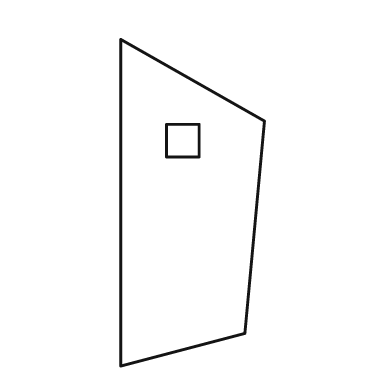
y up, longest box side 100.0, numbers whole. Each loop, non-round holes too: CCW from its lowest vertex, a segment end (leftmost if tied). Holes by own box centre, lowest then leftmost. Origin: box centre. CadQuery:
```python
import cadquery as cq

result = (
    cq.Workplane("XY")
    .moveTo(-22.0, -50.0)
    .lineTo(16.0, -40.0)
    .lineTo(22.0, 25.0)
    .lineTo(-22.0, 50.0)
    .close()
    .moveTo(-8.0, 14.0)
    .lineTo(2.0, 14.0)
    .lineTo(2.0, 24.0)
    .lineTo(-8.0, 24.0)
    .close()
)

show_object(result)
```